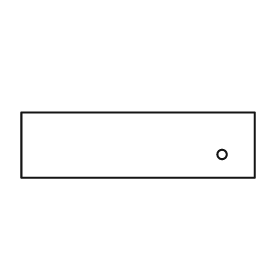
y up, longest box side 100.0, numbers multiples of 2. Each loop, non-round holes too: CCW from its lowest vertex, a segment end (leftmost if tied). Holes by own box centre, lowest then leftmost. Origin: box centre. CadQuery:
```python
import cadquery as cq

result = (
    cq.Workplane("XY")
    .moveTo(-50.0, -14.0)
    .lineTo(50.0, -14.0)
    .lineTo(50.0, 14.0)
    .lineTo(-50.0, 14.0)
    .close()
    .moveTo(36.0, -4.0)
    .circle(2.0)
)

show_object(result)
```